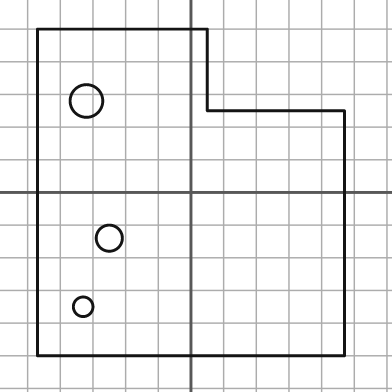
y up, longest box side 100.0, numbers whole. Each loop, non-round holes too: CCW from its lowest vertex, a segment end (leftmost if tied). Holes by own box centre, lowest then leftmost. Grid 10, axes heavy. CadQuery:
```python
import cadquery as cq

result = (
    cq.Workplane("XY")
    .moveTo(-47.0, -50.0)
    .lineTo(47.0, -50.0)
    .lineTo(47.0, 25.0)
    .lineTo(5.0, 25.0)
    .lineTo(5.0, 50.0)
    .lineTo(-47.0, 50.0)
    .close()
    .moveTo(-33.0, -35.0)
    .circle(3.0)
    .moveTo(-25.0, -14.0)
    .circle(4.0)
    .moveTo(-32.0, 28.0)
    .circle(5.0)
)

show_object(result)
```